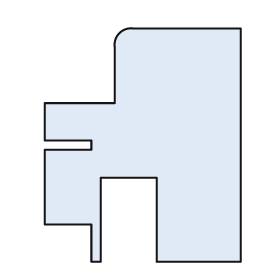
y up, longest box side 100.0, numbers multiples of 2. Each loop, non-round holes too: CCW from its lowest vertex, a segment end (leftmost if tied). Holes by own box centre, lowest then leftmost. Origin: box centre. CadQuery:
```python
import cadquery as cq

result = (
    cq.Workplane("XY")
    .moveTo(-22.0, -50.0)
    .lineTo(-18.0, -50.0)
    .lineTo(-18.0, -14.0)
    .lineTo(6.0, -14.0)
    .lineTo(6.0, -50.0)
    .lineTo(42.0, -50.0)
    .lineTo(42.0, 50.0)
    .lineTo(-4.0, 50.0)
    .threePointArc((-10.0, 48.0), (-12.0, 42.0))
    .lineTo(-12.0, 18.0)
    .lineTo(-42.0, 18.0)
    .lineTo(-42.0, 2.0)
    .lineTo(-22.0, 2.0)
    .lineTo(-22.0, -2.0)
    .lineTo(-42.0, -2.0)
    .lineTo(-42.0, -34.0)
    .lineTo(-22.0, -34.0)
    .close()
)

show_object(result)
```